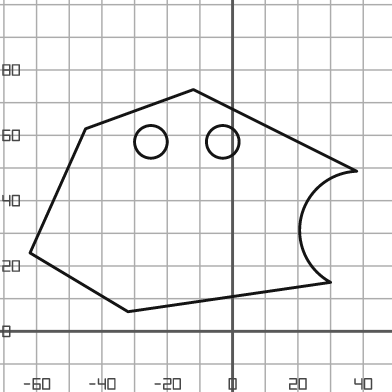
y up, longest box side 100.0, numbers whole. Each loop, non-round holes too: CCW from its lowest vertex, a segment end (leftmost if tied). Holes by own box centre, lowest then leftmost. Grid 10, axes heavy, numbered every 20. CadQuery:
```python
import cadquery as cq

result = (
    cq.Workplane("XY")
    .moveTo(-32.0, 6.0)
    .lineTo(30.0, 15.0)
    .threePointArc((21.0, 35.0), (38.0, 49.0))
    .lineTo(-12.0, 74.0)
    .lineTo(-45.0, 62.0)
    .lineTo(-62.0, 24.0)
    .close()
    .moveTo(-25.0, 58.0)
    .circle(5.0)
    .moveTo(-3.0, 58.0)
    .circle(5.0)
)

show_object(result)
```